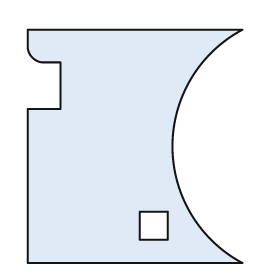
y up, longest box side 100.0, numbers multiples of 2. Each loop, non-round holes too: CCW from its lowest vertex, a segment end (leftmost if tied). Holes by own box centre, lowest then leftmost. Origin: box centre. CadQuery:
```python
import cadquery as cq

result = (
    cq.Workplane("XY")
    .moveTo(-46.0, -50.0)
    .lineTo(46.0, -50.0)
    .threePointArc((16.0, 0.0), (46.0, 50.0))
    .lineTo(-46.0, 50.0)
    .lineTo(-46.0, 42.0)
    .threePointArc((-44.0, 38.0), (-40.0, 36.0))
    .lineTo(-32.0, 36.0)
    .lineTo(-32.0, 16.0)
    .lineTo(-46.0, 16.0)
    .close()
    .moveTo(2.0, -40.0)
    .lineTo(14.0, -40.0)
    .lineTo(14.0, -28.0)
    .lineTo(2.0, -28.0)
    .close()
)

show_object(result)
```